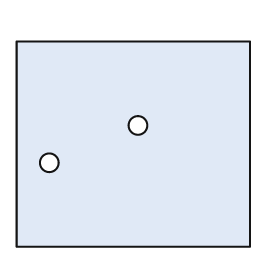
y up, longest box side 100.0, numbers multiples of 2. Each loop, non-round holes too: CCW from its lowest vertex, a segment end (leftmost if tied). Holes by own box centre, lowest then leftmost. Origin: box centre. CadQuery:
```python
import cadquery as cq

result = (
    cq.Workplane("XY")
    .moveTo(-50.0, -44.0)
    .lineTo(50.0, -44.0)
    .lineTo(50.0, 44.0)
    .lineTo(-50.0, 44.0)
    .close()
    .moveTo(-36.0, -8.0)
    .circle(4.0)
    .moveTo(2.0, 8.0)
    .circle(4.0)
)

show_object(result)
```